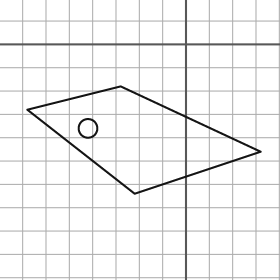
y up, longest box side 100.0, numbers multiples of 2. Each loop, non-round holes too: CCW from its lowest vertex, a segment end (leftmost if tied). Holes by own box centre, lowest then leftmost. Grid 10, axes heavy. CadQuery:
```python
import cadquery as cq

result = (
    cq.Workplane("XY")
    .moveTo(-22.0, -64.0)
    .lineTo(32.0, -46.0)
    .lineTo(-28.0, -18.0)
    .lineTo(-68.0, -28.0)
    .close()
    .moveTo(-42.0, -36.0)
    .circle(4.0)
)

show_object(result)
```